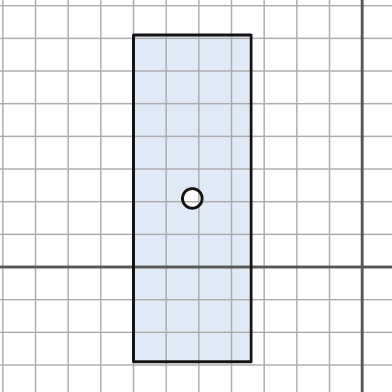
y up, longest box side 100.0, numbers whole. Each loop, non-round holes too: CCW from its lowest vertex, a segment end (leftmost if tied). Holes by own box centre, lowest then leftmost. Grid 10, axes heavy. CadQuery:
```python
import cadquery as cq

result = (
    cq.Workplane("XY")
    .moveTo(-70.0, -29.0)
    .lineTo(-34.0, -29.0)
    .lineTo(-34.0, 71.0)
    .lineTo(-70.0, 71.0)
    .close()
    .moveTo(-52.0, 21.0)
    .circle(3.0)
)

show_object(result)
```